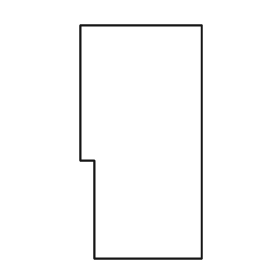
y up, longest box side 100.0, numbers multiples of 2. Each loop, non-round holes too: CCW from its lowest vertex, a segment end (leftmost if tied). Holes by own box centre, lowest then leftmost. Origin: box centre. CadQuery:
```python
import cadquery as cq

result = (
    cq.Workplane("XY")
    .moveTo(-20.0, -50.0)
    .lineTo(26.0, -50.0)
    .lineTo(26.0, 50.0)
    .lineTo(-26.0, 50.0)
    .lineTo(-26.0, -8.0)
    .lineTo(-20.0, -8.0)
    .close()
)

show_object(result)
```